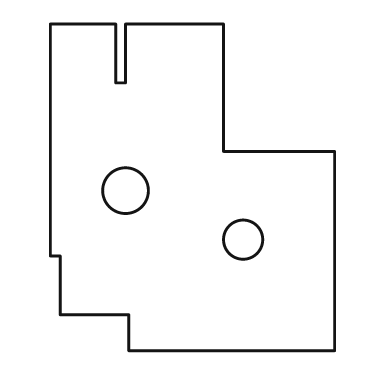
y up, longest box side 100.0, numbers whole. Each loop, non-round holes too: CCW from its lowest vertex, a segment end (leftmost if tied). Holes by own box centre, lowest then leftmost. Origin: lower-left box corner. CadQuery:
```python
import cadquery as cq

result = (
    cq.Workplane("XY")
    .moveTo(24.0, 0.0)
    .lineTo(87.0, 0.0)
    .lineTo(87.0, 61.0)
    .lineTo(53.0, 61.0)
    .lineTo(53.0, 100.0)
    .lineTo(23.0, 100.0)
    .lineTo(23.0, 82.0)
    .lineTo(20.0, 82.0)
    .lineTo(20.0, 100.0)
    .lineTo(0.0, 100.0)
    .lineTo(0.0, 29.0)
    .lineTo(3.0, 29.0)
    .lineTo(3.0, 11.0)
    .lineTo(24.0, 11.0)
    .close()
    .moveTo(59.0, 34.0)
    .circle(6.0)
    .moveTo(23.0, 49.0)
    .circle(7.0)
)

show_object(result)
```